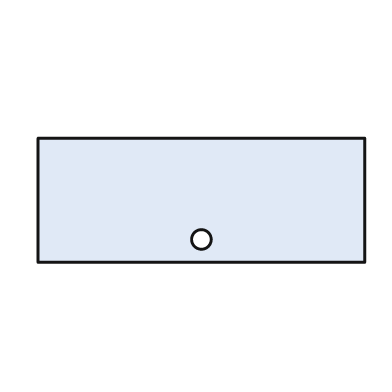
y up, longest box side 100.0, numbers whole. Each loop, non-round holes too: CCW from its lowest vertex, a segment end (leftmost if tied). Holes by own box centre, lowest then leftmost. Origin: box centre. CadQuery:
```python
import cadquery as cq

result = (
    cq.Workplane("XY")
    .moveTo(-50.0, -19.0)
    .lineTo(50.0, -19.0)
    .lineTo(50.0, 19.0)
    .lineTo(-50.0, 19.0)
    .close()
    .moveTo(0.0, -12.0)
    .circle(3.0)
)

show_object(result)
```